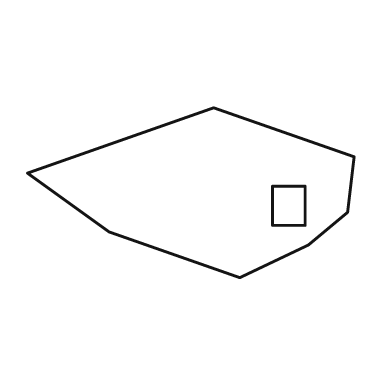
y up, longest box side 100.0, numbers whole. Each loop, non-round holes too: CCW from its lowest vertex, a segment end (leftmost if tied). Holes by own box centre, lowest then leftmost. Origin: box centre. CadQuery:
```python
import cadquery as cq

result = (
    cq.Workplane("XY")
    .moveTo(15.0, -26.0)
    .lineTo(36.0, -16.0)
    .lineTo(48.0, -6.0)
    .lineTo(50.0, 11.0)
    .lineTo(7.0, 26.0)
    .lineTo(-50.0, 6.0)
    .lineTo(-25.0, -12.0)
    .close()
    .moveTo(25.0, -10.0)
    .lineTo(35.0, -10.0)
    .lineTo(35.0, 2.0)
    .lineTo(25.0, 2.0)
    .close()
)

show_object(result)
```